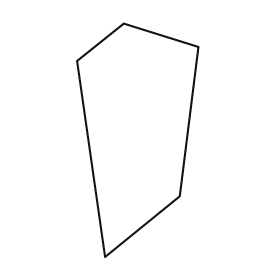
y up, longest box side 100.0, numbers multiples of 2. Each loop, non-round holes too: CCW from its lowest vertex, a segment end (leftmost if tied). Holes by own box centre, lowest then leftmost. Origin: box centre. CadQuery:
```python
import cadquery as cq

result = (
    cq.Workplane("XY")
    .moveTo(-14.0, -50.0)
    .lineTo(18.0, -24.0)
    .lineTo(26.0, 40.0)
    .lineTo(-6.0, 50.0)
    .lineTo(-26.0, 34.0)
    .close()
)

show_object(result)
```